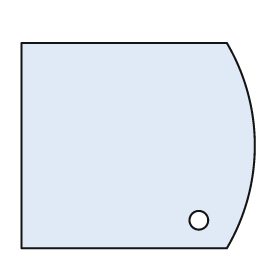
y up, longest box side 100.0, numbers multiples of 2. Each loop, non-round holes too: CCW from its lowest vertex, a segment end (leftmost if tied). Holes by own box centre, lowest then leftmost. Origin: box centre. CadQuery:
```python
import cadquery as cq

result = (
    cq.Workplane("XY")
    .moveTo(-50.0, -44.0)
    .lineTo(38.0, -44.0)
    .threePointArc((50.0, 0.0), (38.0, 44.0))
    .lineTo(-50.0, 44.0)
    .close()
    .moveTo(26.0, -32.0)
    .circle(4.0)
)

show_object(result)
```